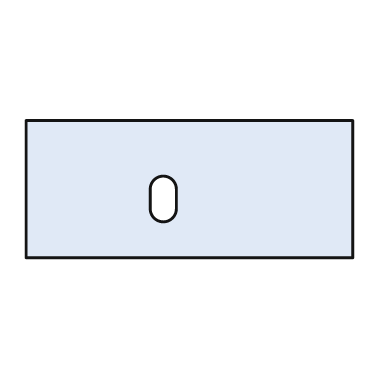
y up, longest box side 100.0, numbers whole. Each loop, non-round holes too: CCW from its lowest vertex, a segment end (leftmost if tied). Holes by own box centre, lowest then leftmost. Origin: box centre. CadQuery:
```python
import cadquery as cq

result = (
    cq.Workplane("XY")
    .moveTo(-50.0, -21.0)
    .lineTo(50.0, -21.0)
    .lineTo(50.0, 21.0)
    .lineTo(-50.0, 21.0)
    .close()
    .moveTo(-12.0, -6.0)
    .threePointArc((-8.0, -10.0), (-4.0, -6.0))
    .lineTo(-4.0, 0.0)
    .threePointArc((-8.0, 4.0), (-12.0, 0.0))
    .close()
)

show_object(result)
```